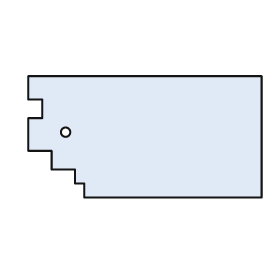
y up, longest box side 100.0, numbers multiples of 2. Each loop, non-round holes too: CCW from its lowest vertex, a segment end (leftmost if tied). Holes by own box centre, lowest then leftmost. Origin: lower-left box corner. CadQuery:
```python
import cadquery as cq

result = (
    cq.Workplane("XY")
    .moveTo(24.0, 0.0)
    .lineTo(100.0, 0.0)
    .lineTo(100.0, 52.0)
    .lineTo(0.0, 52.0)
    .lineTo(0.0, 42.0)
    .lineTo(6.0, 42.0)
    .lineTo(6.0, 34.0)
    .lineTo(0.0, 34.0)
    .lineTo(0.0, 20.0)
    .lineTo(10.0, 20.0)
    .lineTo(10.0, 12.0)
    .lineTo(20.0, 12.0)
    .lineTo(20.0, 6.0)
    .lineTo(24.0, 6.0)
    .close()
    .moveTo(16.0, 28.0)
    .circle(2.0)
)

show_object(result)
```